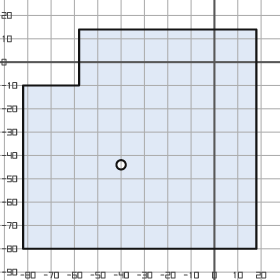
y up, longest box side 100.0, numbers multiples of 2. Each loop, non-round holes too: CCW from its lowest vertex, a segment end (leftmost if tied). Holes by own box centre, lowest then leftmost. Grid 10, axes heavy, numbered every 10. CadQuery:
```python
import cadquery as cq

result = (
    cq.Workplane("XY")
    .moveTo(-82.0, -80.0)
    .lineTo(18.0, -80.0)
    .lineTo(18.0, 14.0)
    .lineTo(-58.0, 14.0)
    .lineTo(-58.0, -10.0)
    .lineTo(-82.0, -10.0)
    .close()
    .moveTo(-40.0, -44.0)
    .circle(2.0)
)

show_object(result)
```